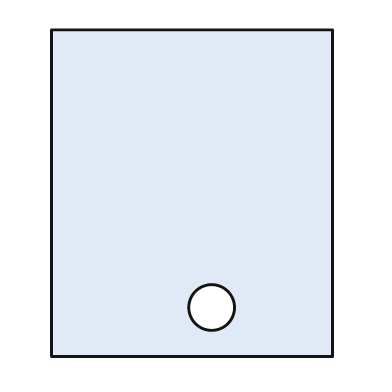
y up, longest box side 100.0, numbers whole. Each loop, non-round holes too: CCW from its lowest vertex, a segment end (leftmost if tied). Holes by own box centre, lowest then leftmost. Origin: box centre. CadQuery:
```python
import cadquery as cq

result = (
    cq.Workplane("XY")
    .moveTo(-43.0, -50.0)
    .lineTo(43.0, -50.0)
    .lineTo(43.0, 50.0)
    .lineTo(-43.0, 50.0)
    .close()
    .moveTo(6.0, -35.0)
    .circle(7.0)
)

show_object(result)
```